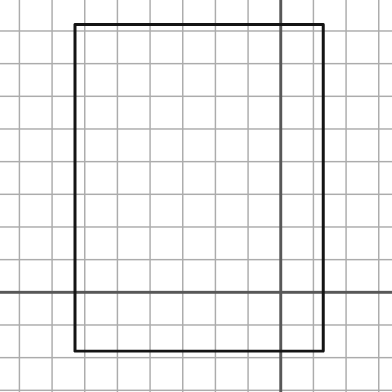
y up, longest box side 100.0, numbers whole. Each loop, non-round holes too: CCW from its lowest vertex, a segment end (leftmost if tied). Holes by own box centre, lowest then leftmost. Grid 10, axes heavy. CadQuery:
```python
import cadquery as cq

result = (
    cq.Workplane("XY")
    .moveTo(-63.0, -18.0)
    .lineTo(13.0, -18.0)
    .lineTo(13.0, 82.0)
    .lineTo(-63.0, 82.0)
    .close()
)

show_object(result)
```